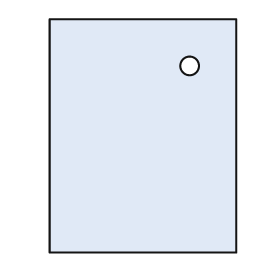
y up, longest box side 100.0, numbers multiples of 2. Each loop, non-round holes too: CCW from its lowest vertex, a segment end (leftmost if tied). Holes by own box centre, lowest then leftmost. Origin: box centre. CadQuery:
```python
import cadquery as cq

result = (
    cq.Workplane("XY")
    .moveTo(-40.0, -50.0)
    .lineTo(40.0, -50.0)
    .lineTo(40.0, 50.0)
    .lineTo(-40.0, 50.0)
    .close()
    .moveTo(20.0, 30.0)
    .circle(4.0)
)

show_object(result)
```